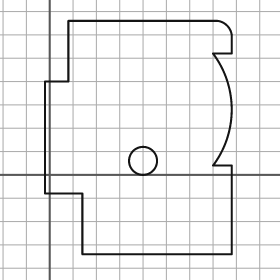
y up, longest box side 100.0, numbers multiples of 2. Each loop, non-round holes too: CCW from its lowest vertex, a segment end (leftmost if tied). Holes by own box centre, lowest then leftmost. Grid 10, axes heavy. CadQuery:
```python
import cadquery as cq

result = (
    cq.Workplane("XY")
    .moveTo(14.0, -34.0)
    .lineTo(78.0, -34.0)
    .lineTo(78.0, 4.0)
    .lineTo(70.0, 4.0)
    .threePointArc((78.0, 28.0), (70.0, 52.0))
    .lineTo(78.0, 52.0)
    .lineTo(78.0, 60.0)
    .threePointArc((76.0, 64.0), (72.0, 66.0))
    .lineTo(8.0, 66.0)
    .lineTo(8.0, 40.0)
    .lineTo(-2.0, 40.0)
    .lineTo(-2.0, -8.0)
    .lineTo(14.0, -8.0)
    .close()
    .moveTo(40.0, 6.0)
    .circle(6.0)
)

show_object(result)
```